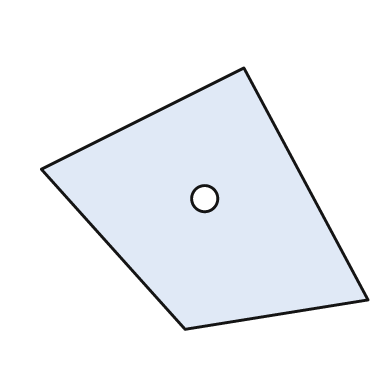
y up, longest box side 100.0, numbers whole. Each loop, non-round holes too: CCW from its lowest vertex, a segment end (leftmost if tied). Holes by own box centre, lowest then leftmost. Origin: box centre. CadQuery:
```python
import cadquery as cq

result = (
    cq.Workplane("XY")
    .moveTo(-6.0, -40.0)
    .lineTo(50.0, -31.0)
    .lineTo(12.0, 40.0)
    .lineTo(-50.0, 9.0)
    .close()
    .moveTo(0.0, 0.0)
    .circle(4.0)
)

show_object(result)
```